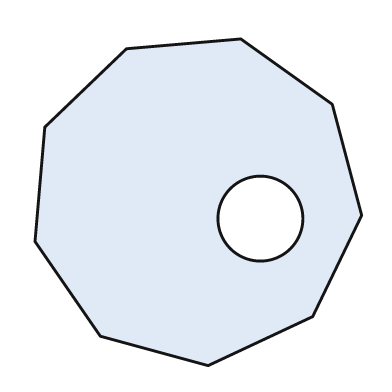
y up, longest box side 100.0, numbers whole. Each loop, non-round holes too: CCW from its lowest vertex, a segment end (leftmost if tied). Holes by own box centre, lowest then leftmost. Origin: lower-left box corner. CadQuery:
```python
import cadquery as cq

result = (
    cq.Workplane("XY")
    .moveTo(53.0, 0.0)
    .lineTo(85.0, 15.0)
    .lineTo(100.0, 46.0)
    .lineTo(91.0, 80.0)
    .lineTo(63.0, 100.0)
    .lineTo(28.0, 97.0)
    .lineTo(3.0, 73.0)
    .lineTo(0.0, 38.0)
    .lineTo(20.0, 9.0)
    .close()
    .moveTo(69.0, 45.0)
    .circle(13.0)
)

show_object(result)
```